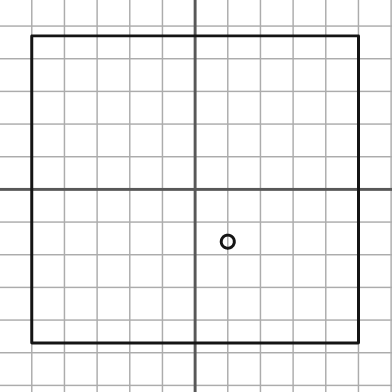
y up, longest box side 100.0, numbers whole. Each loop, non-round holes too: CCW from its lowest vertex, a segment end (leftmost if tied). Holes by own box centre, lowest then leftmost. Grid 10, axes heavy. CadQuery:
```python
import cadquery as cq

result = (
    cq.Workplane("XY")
    .moveTo(-50.0, -47.0)
    .lineTo(50.0, -47.0)
    .lineTo(50.0, 47.0)
    .lineTo(-50.0, 47.0)
    .close()
    .moveTo(10.0, -16.0)
    .circle(2.0)
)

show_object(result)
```